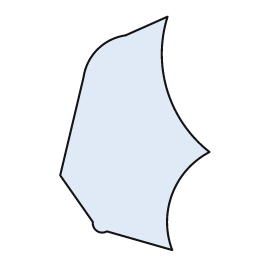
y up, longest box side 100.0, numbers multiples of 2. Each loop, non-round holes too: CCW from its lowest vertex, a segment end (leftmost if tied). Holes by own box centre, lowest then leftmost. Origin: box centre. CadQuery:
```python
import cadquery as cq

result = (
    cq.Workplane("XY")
    .moveTo(16.0, -50.0)
    .threePointArc((16.0, -26.0), (32.0, -8.0))
    .threePointArc((14.0, 18.0), (14.0, 50.0))
    .lineTo(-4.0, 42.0)
    .threePointArc((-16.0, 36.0), (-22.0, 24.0))
    .lineTo(-32.0, -18.0)
    .lineTo(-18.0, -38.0)
    .threePointArc((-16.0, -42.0), (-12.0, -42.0))
    .close()
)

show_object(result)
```